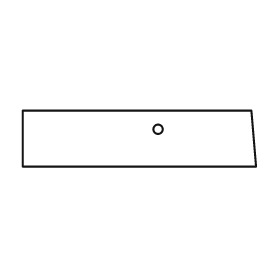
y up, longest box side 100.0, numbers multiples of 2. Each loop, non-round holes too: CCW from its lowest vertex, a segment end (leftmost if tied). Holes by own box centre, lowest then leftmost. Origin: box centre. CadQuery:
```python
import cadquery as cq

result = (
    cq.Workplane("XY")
    .moveTo(-50.0, -12.0)
    .lineTo(50.0, -12.0)
    .lineTo(48.0, 12.0)
    .lineTo(-50.0, 12.0)
    .close()
    .moveTo(8.0, 4.0)
    .circle(2.0)
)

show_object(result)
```